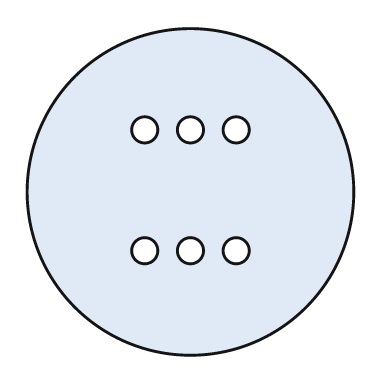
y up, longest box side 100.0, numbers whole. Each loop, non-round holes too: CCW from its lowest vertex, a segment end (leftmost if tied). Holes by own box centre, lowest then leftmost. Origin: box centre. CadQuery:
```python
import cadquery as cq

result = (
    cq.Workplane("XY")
    .moveTo(0.0, 0.0)
    .circle(50.0)
    .moveTo(-14.0, -18.0)
    .circle(4.0)
    .moveTo(0.0, -18.0)
    .circle(4.0)
    .moveTo(14.0, -18.0)
    .circle(4.0)
    .moveTo(-14.0, 19.0)
    .circle(4.0)
    .moveTo(0.0, 19.0)
    .circle(4.0)
    .moveTo(14.0, 19.0)
    .circle(4.0)
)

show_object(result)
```